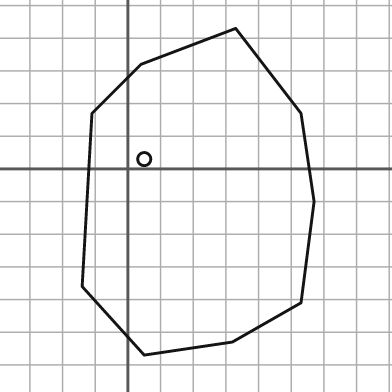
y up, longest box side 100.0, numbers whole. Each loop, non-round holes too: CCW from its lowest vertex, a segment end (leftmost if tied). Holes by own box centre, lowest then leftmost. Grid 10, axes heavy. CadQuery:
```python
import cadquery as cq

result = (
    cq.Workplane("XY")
    .moveTo(5.0, -57.0)
    .lineTo(32.0, -53.0)
    .lineTo(53.0, -41.0)
    .lineTo(57.0, -10.0)
    .lineTo(53.0, 17.0)
    .lineTo(33.0, 43.0)
    .lineTo(4.0, 32.0)
    .lineTo(-11.0, 17.0)
    .lineTo(-14.0, -36.0)
    .close()
    .moveTo(5.0, 3.0)
    .circle(2.0)
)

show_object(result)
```